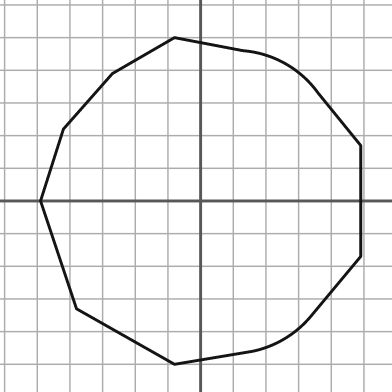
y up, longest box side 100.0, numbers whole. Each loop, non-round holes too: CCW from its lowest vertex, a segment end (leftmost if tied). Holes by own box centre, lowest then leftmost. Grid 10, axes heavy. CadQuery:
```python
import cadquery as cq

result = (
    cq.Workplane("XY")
    .moveTo(-8.0, -50.0)
    .lineTo(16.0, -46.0)
    .threePointArc((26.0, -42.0), (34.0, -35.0))
    .lineTo(49.0, -17.0)
    .lineTo(49.0, 17.0)
    .lineTo(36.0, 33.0)
    .threePointArc((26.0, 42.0), (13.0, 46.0))
    .lineTo(-8.0, 50.0)
    .lineTo(-27.0, 39.0)
    .lineTo(-42.0, 22.0)
    .lineTo(-49.0, 0.0)
    .lineTo(-38.0, -33.0)
    .close()
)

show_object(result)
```